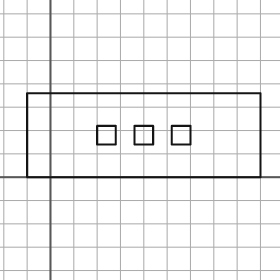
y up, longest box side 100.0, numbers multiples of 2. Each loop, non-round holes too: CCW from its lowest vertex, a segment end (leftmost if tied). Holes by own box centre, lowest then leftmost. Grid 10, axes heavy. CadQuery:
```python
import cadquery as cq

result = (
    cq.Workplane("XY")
    .moveTo(-10.0, 0.0)
    .lineTo(90.0, 0.0)
    .lineTo(90.0, 36.0)
    .lineTo(-10.0, 36.0)
    .close()
    .moveTo(20.0, 14.0)
    .lineTo(28.0, 14.0)
    .lineTo(28.0, 22.0)
    .lineTo(20.0, 22.0)
    .close()
    .moveTo(36.0, 14.0)
    .lineTo(44.0, 14.0)
    .lineTo(44.0, 22.0)
    .lineTo(36.0, 22.0)
    .close()
    .moveTo(52.0, 14.0)
    .lineTo(60.0, 14.0)
    .lineTo(60.0, 22.0)
    .lineTo(52.0, 22.0)
    .close()
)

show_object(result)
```